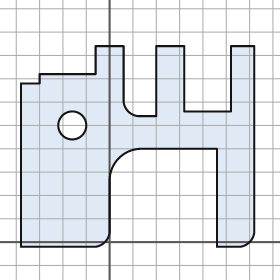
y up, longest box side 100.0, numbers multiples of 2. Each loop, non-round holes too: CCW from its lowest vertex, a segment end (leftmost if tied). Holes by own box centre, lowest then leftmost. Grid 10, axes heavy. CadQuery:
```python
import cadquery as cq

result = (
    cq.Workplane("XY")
    .moveTo(-38.0, -2.0)
    .lineTo(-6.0, -2.0)
    .threePointArc((-2.0, 0.0), (0.0, 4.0))
    .lineTo(0.0, 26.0)
    .threePointArc((4.0, 36.0), (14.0, 40.0))
    .lineTo(46.0, 40.0)
    .lineTo(46.0, -2.0)
    .lineTo(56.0, -2.0)
    .threePointArc((60.0, 0.0), (62.0, 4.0))
    .lineTo(62.0, 84.0)
    .lineTo(52.0, 84.0)
    .lineTo(52.0, 56.0)
    .lineTo(32.0, 56.0)
    .lineTo(32.0, 84.0)
    .lineTo(20.0, 84.0)
    .lineTo(20.0, 54.0)
    .lineTo(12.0, 54.0)
    .threePointArc((8.0, 56.0), (6.0, 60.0))
    .lineTo(6.0, 84.0)
    .lineTo(-6.0, 84.0)
    .lineTo(-6.0, 72.0)
    .lineTo(-30.0, 72.0)
    .lineTo(-30.0, 68.0)
    .lineTo(-38.0, 68.0)
    .close()
    .moveTo(-16.0, 50.0)
    .circle(6.0)
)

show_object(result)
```